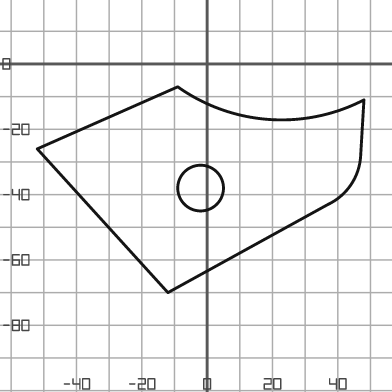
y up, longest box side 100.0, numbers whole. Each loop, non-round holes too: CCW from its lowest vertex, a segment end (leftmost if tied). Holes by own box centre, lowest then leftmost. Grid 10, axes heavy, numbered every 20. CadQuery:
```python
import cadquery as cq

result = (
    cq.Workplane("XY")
    .moveTo(-12.0, -70.0)
    .lineTo(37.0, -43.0)
    .threePointArc((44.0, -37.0), (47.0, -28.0))
    .lineTo(48.0, -11.0)
    .threePointArc((19.0, -17.0), (-9.0, -7.0))
    .lineTo(-52.0, -26.0)
    .close()
    .moveTo(-2.0, -38.0)
    .circle(7.0)
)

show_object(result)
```